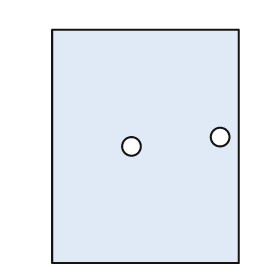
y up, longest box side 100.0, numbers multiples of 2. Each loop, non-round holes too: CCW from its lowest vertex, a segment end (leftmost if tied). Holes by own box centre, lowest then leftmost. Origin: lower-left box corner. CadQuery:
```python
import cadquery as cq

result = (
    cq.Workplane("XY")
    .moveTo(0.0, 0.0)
    .lineTo(80.0, 0.0)
    .lineTo(80.0, 100.0)
    .lineTo(0.0, 100.0)
    .close()
    .moveTo(34.0, 50.0)
    .circle(4.0)
    .moveTo(72.0, 54.0)
    .circle(4.0)
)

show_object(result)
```